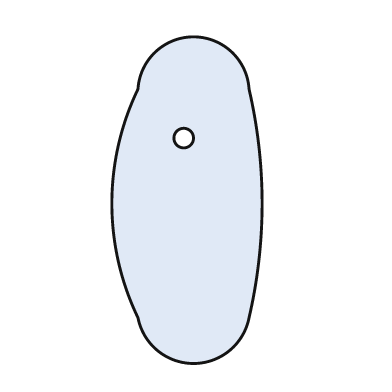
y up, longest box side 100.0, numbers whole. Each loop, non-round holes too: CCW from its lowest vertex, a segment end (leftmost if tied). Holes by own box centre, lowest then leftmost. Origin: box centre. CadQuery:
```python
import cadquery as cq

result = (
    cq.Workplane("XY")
    .moveTo(-15.0, -36.0)
    .threePointArc((2.0, -50.0), (19.0, -36.0))
    .threePointArc((23.0, -1.0), (19.0, 34.0))
    .threePointArc((2.0, 50.0), (-15.0, 34.0))
    .threePointArc((-23.0, -1.0), (-15.0, -36.0))
    .close()
    .moveTo(-1.0, 19.0)
    .circle(3.0)
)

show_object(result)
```